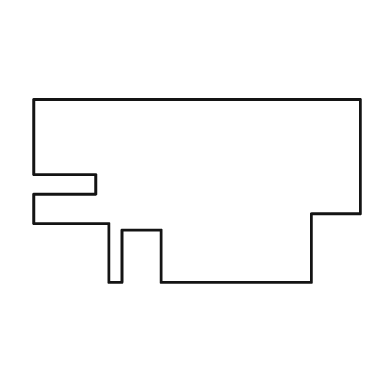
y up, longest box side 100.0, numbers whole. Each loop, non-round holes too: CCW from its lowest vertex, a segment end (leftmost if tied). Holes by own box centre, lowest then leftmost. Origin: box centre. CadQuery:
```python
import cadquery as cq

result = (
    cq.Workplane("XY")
    .moveTo(-27.0, -28.0)
    .lineTo(-23.0, -28.0)
    .lineTo(-23.0, -12.0)
    .lineTo(-11.0, -12.0)
    .lineTo(-11.0, -28.0)
    .lineTo(35.0, -28.0)
    .lineTo(35.0, -7.0)
    .lineTo(50.0, -7.0)
    .lineTo(50.0, 28.0)
    .lineTo(-50.0, 28.0)
    .lineTo(-50.0, 5.0)
    .lineTo(-31.0, 5.0)
    .lineTo(-31.0, -1.0)
    .lineTo(-50.0, -1.0)
    .lineTo(-50.0, -10.0)
    .lineTo(-27.0, -10.0)
    .close()
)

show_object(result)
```